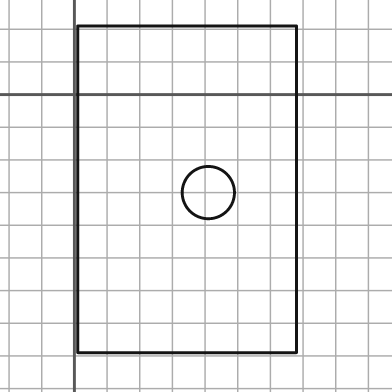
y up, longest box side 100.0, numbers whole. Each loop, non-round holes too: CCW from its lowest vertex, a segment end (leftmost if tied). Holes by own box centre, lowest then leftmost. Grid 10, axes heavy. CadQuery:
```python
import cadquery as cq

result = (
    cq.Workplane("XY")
    .moveTo(1.0, -79.0)
    .lineTo(68.0, -79.0)
    .lineTo(68.0, 21.0)
    .lineTo(1.0, 21.0)
    .close()
    .moveTo(41.0, -30.0)
    .circle(8.0)
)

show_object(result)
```